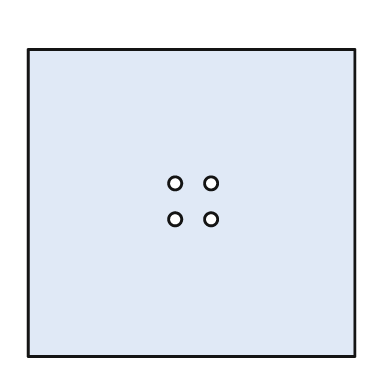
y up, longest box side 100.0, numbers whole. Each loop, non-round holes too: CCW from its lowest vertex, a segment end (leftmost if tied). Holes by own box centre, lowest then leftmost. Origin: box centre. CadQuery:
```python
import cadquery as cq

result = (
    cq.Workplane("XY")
    .moveTo(-50.0, -47.0)
    .lineTo(50.0, -47.0)
    .lineTo(50.0, 47.0)
    .lineTo(-50.0, 47.0)
    .close()
    .moveTo(-5.0, -5.0)
    .circle(2.0)
    .moveTo(6.0, -5.0)
    .circle(2.0)
    .moveTo(-5.0, 6.0)
    .circle(2.0)
    .moveTo(6.0, 6.0)
    .circle(2.0)
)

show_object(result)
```